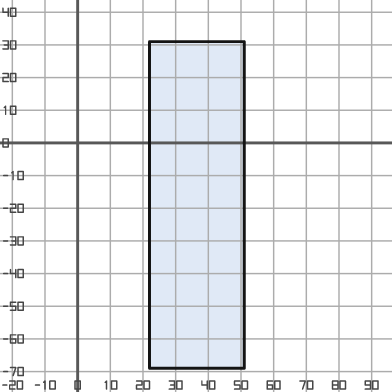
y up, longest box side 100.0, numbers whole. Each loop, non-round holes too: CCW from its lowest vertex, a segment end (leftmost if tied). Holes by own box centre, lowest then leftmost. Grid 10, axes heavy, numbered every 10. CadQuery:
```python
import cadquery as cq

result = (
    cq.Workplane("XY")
    .moveTo(22.0, -69.0)
    .lineTo(51.0, -69.0)
    .lineTo(51.0, 31.0)
    .lineTo(22.0, 31.0)
    .close()
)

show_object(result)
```